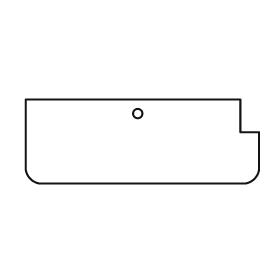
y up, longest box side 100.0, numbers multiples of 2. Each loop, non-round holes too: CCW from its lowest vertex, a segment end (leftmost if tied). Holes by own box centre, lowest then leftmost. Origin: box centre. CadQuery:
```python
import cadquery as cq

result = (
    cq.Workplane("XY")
    .moveTo(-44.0, -18.0)
    .lineTo(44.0, -18.0)
    .threePointArc((48.0, -16.0), (50.0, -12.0))
    .lineTo(50.0, 4.0)
    .lineTo(42.0, 4.0)
    .lineTo(42.0, 18.0)
    .lineTo(-50.0, 18.0)
    .lineTo(-50.0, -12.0)
    .threePointArc((-48.0, -16.0), (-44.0, -18.0))
    .close()
    .moveTo(-2.0, 12.0)
    .circle(2.0)
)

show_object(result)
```